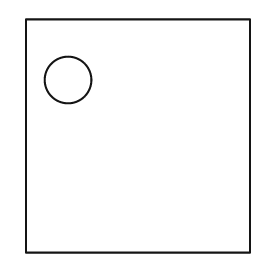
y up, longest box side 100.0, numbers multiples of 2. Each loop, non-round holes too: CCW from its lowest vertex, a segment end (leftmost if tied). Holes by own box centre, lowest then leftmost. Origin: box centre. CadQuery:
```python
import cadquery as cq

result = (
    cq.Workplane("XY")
    .moveTo(-48.0, -50.0)
    .lineTo(48.0, -50.0)
    .lineTo(48.0, 50.0)
    .lineTo(-48.0, 50.0)
    .close()
    .moveTo(-30.0, 24.0)
    .circle(10.0)
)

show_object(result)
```